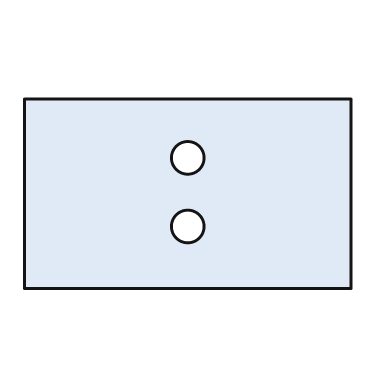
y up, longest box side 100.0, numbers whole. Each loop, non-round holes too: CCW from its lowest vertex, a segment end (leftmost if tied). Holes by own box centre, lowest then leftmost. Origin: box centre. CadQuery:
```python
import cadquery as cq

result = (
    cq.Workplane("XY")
    .moveTo(-50.0, -29.0)
    .lineTo(50.0, -29.0)
    .lineTo(50.0, 29.0)
    .lineTo(-50.0, 29.0)
    .close()
    .moveTo(0.0, -10.0)
    .circle(5.0)
    .moveTo(0.0, 11.0)
    .circle(5.0)
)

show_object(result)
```